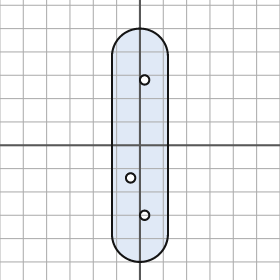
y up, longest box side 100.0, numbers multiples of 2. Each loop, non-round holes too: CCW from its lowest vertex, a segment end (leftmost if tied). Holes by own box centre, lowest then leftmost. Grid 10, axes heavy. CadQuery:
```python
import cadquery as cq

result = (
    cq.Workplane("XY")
    .moveTo(-12.0, -38.0)
    .threePointArc((0.0, -50.0), (12.0, -38.0))
    .lineTo(12.0, 38.0)
    .threePointArc((0.0, 50.0), (-12.0, 38.0))
    .close()
    .moveTo(2.0, -30.0)
    .circle(2.0)
    .moveTo(-4.0, -14.0)
    .circle(2.0)
    .moveTo(2.0, 28.0)
    .circle(2.0)
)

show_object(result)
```